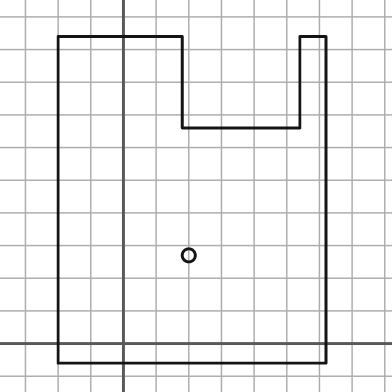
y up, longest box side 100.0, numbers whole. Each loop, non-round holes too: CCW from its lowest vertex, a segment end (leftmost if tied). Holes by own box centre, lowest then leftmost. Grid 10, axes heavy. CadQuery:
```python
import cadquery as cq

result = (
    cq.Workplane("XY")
    .moveTo(-20.0, -6.0)
    .lineTo(62.0, -6.0)
    .lineTo(62.0, 94.0)
    .lineTo(54.0, 94.0)
    .lineTo(54.0, 66.0)
    .lineTo(18.0, 66.0)
    .lineTo(18.0, 94.0)
    .lineTo(-20.0, 94.0)
    .close()
    .moveTo(20.0, 27.0)
    .circle(2.0)
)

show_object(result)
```